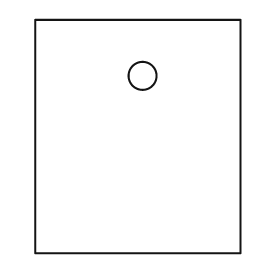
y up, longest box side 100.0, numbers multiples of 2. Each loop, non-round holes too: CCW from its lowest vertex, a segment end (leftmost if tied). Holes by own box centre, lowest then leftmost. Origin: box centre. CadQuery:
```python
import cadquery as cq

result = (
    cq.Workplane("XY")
    .moveTo(-44.0, -50.0)
    .lineTo(44.0, -50.0)
    .lineTo(44.0, 50.0)
    .lineTo(-44.0, 50.0)
    .close()
    .moveTo(2.0, 26.0)
    .circle(6.0)
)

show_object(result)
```